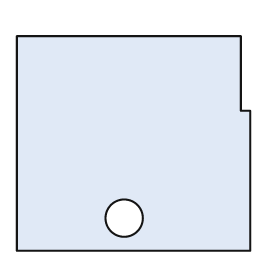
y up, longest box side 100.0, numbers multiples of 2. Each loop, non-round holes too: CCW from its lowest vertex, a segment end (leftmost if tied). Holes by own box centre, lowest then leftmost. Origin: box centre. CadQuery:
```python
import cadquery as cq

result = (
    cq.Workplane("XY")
    .moveTo(-50.0, -46.0)
    .lineTo(50.0, -46.0)
    .lineTo(50.0, 14.0)
    .lineTo(46.0, 14.0)
    .lineTo(46.0, 46.0)
    .lineTo(-50.0, 46.0)
    .close()
    .moveTo(-4.0, -32.0)
    .circle(8.0)
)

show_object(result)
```